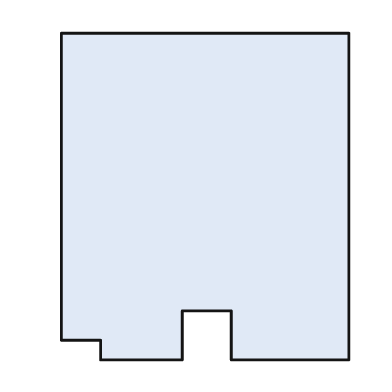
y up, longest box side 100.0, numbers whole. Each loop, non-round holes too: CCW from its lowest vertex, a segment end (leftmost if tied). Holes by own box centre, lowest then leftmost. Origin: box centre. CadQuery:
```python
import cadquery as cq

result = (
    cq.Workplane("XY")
    .moveTo(-32.0, -50.0)
    .lineTo(-7.0, -50.0)
    .lineTo(-7.0, -35.0)
    .lineTo(8.0, -35.0)
    .lineTo(8.0, -50.0)
    .lineTo(44.0, -50.0)
    .lineTo(44.0, 50.0)
    .lineTo(-44.0, 50.0)
    .lineTo(-44.0, -44.0)
    .lineTo(-32.0, -44.0)
    .close()
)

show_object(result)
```